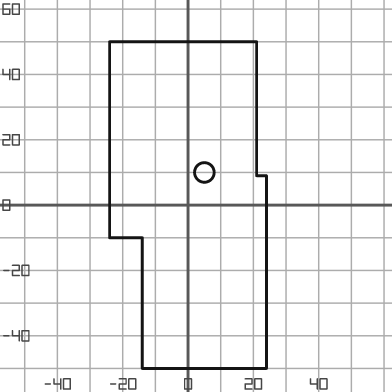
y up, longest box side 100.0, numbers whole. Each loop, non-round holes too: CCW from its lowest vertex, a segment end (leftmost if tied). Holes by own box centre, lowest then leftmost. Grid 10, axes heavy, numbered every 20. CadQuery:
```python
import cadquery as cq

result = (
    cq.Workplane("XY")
    .moveTo(-14.0, -50.0)
    .lineTo(24.0, -50.0)
    .lineTo(24.0, 9.0)
    .lineTo(21.0, 9.0)
    .lineTo(21.0, 50.0)
    .lineTo(-24.0, 50.0)
    .lineTo(-24.0, -10.0)
    .lineTo(-14.0, -10.0)
    .close()
    .moveTo(5.0, 10.0)
    .circle(3.0)
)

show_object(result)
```